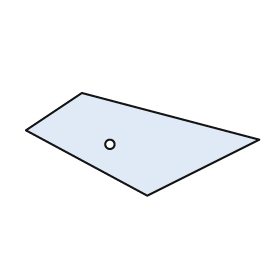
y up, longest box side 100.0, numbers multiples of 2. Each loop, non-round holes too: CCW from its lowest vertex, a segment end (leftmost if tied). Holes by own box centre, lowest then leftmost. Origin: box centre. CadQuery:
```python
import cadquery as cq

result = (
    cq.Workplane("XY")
    .moveTo(2.0, -22.0)
    .lineTo(50.0, 2.0)
    .lineTo(-26.0, 22.0)
    .lineTo(-50.0, 6.0)
    .close()
    .moveTo(-14.0, 0.0)
    .circle(2.0)
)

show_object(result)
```